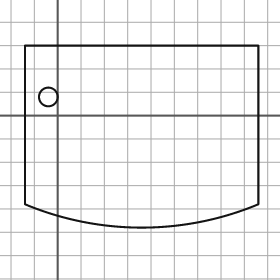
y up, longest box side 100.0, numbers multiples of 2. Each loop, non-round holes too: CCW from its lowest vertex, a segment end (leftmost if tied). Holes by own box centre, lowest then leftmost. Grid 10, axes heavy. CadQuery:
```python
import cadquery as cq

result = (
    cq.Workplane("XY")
    .moveTo(-14.0, -38.0)
    .threePointArc((36.0, -48.0), (86.0, -38.0))
    .lineTo(86.0, 30.0)
    .lineTo(-14.0, 30.0)
    .close()
    .moveTo(-4.0, 8.0)
    .circle(4.0)
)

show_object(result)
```